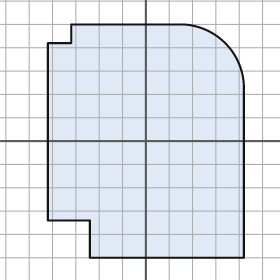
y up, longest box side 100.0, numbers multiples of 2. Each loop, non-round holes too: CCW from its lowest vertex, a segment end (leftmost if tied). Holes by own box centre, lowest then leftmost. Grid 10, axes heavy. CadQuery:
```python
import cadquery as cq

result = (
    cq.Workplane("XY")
    .moveTo(-24.0, -50.0)
    .lineTo(42.0, -50.0)
    .lineTo(42.0, 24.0)
    .threePointArc((34.0, 42.0), (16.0, 50.0))
    .lineTo(-32.0, 50.0)
    .lineTo(-32.0, 42.0)
    .lineTo(-42.0, 42.0)
    .lineTo(-42.0, -34.0)
    .lineTo(-24.0, -34.0)
    .close()
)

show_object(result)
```